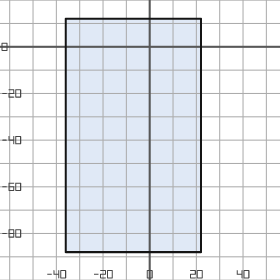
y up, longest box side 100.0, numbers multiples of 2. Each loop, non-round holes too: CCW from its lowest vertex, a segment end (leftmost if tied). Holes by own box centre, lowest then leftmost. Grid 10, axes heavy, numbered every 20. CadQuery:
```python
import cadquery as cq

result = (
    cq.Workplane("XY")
    .moveTo(-36.0, -88.0)
    .lineTo(22.0, -88.0)
    .lineTo(22.0, 12.0)
    .lineTo(-36.0, 12.0)
    .close()
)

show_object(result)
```